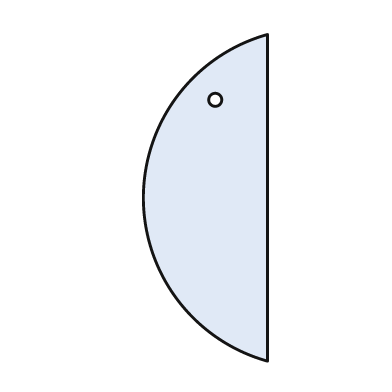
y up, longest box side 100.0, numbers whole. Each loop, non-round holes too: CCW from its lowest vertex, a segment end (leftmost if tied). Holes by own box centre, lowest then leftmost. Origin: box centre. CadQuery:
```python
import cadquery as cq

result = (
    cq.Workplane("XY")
    .moveTo(19.0, -50.0)
    .lineTo(19.0, 50.0)
    .threePointArc((-19.0, 0.0), (19.0, -50.0))
    .close()
    .moveTo(3.0, 30.0)
    .circle(2.0)
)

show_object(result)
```